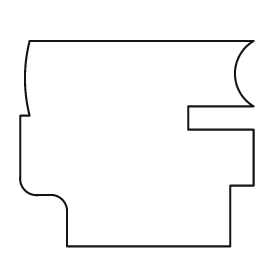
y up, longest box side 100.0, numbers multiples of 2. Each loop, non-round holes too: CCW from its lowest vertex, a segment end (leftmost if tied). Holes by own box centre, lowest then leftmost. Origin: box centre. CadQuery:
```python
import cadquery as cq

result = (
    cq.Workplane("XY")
    .moveTo(-30.0, -44.0)
    .lineTo(40.0, -44.0)
    .lineTo(40.0, -18.0)
    .lineTo(50.0, -18.0)
    .lineTo(50.0, 6.0)
    .lineTo(22.0, 6.0)
    .lineTo(22.0, 16.0)
    .lineTo(50.0, 16.0)
    .threePointArc((42.0, 30.0), (50.0, 44.0))
    .lineTo(-46.0, 44.0)
    .threePointArc((-48.0, 28.0), (-46.0, 12.0))
    .lineTo(-50.0, 12.0)
    .lineTo(-50.0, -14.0)
    .threePointArc((-48.0, -20.0), (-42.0, -22.0))
    .lineTo(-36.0, -22.0)
    .threePointArc((-32.0, -24.0), (-30.0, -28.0))
    .close()
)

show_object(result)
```